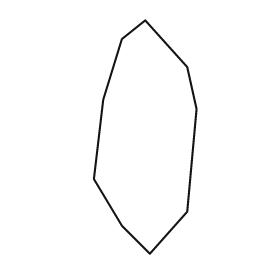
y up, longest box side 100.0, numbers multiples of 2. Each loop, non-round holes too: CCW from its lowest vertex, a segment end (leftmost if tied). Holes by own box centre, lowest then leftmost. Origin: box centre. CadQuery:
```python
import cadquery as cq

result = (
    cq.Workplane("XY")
    .moveTo(2.0, -50.0)
    .lineTo(18.0, -32.0)
    .lineTo(22.0, 12.0)
    .lineTo(18.0, 30.0)
    .lineTo(0.0, 50.0)
    .lineTo(-10.0, 42.0)
    .lineTo(-18.0, 16.0)
    .lineTo(-22.0, -18.0)
    .lineTo(-10.0, -38.0)
    .close()
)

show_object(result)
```